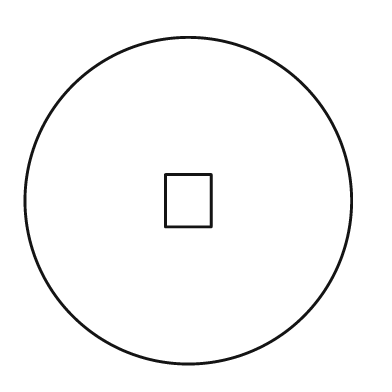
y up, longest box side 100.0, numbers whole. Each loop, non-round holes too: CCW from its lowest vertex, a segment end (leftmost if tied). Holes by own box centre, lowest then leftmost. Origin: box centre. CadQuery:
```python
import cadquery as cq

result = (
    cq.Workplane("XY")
    .moveTo(0.0, 0.0)
    .circle(50.0)
    .moveTo(-7.0, -8.0)
    .lineTo(7.0, -8.0)
    .lineTo(7.0, 8.0)
    .lineTo(-7.0, 8.0)
    .close()
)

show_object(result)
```